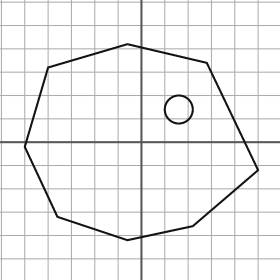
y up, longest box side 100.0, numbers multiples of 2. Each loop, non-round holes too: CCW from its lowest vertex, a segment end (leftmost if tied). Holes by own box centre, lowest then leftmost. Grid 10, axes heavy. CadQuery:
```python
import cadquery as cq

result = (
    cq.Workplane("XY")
    .moveTo(-6.0, -42.0)
    .lineTo(22.0, -36.0)
    .lineTo(50.0, -12.0)
    .lineTo(28.0, 34.0)
    .lineTo(-6.0, 42.0)
    .lineTo(-40.0, 32.0)
    .lineTo(-50.0, -2.0)
    .lineTo(-36.0, -32.0)
    .close()
    .moveTo(16.0, 14.0)
    .circle(6.0)
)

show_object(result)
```